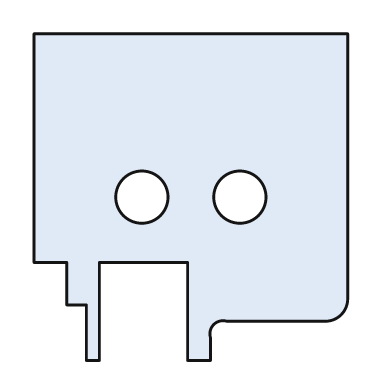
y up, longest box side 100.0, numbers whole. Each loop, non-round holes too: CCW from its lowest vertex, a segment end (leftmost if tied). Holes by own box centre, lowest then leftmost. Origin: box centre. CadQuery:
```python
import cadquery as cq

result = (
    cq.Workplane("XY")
    .moveTo(-32.0, -50.0)
    .lineTo(-28.0, -50.0)
    .lineTo(-28.0, -20.0)
    .lineTo(-1.0, -20.0)
    .lineTo(-1.0, -50.0)
    .lineTo(6.0, -50.0)
    .lineTo(6.0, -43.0)
    .threePointArc((7.0, -39.0), (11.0, -38.0))
    .lineTo(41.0, -38.0)
    .threePointArc((46.0, -36.0), (48.0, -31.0))
    .lineTo(48.0, 50.0)
    .lineTo(-48.0, 50.0)
    .lineTo(-48.0, -20.0)
    .lineTo(-38.0, -20.0)
    .lineTo(-38.0, -33.0)
    .lineTo(-32.0, -33.0)
    .close()
    .moveTo(-15.0, 0.0)
    .circle(8.0)
    .moveTo(15.0, 0.0)
    .circle(8.0)
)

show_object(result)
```